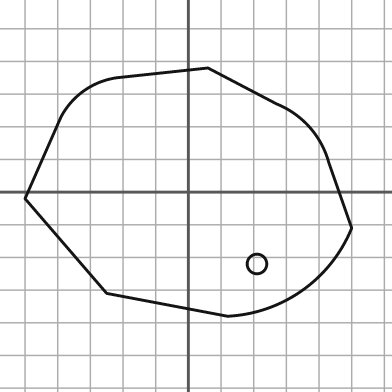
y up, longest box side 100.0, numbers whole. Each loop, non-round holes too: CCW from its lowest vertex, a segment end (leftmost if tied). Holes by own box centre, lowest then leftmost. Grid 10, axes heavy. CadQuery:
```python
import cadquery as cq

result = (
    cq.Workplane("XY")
    .moveTo(12.0, -38.0)
    .threePointArc((35.0, -30.0), (50.0, -11.0))
    .lineTo(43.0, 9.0)
    .threePointArc((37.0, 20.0), (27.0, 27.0))
    .lineTo(6.0, 38.0)
    .lineTo(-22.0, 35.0)
    .threePointArc((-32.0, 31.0), (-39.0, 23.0))
    .lineTo(-50.0, -2.0)
    .lineTo(-25.0, -31.0)
    .close()
    .moveTo(21.0, -22.0)
    .circle(3.0)
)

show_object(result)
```